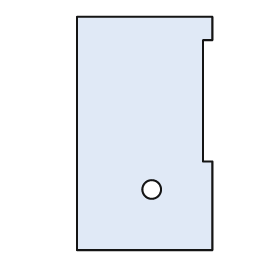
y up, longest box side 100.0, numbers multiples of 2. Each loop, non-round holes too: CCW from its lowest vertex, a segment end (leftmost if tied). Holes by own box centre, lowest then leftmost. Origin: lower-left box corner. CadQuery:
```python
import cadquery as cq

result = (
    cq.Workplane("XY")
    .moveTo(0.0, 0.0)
    .lineTo(58.0, 0.0)
    .lineTo(58.0, 38.0)
    .lineTo(54.0, 38.0)
    .lineTo(54.0, 90.0)
    .lineTo(58.0, 90.0)
    .lineTo(58.0, 100.0)
    .lineTo(0.0, 100.0)
    .close()
    .moveTo(32.0, 26.0)
    .circle(4.0)
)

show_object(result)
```